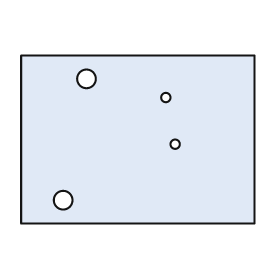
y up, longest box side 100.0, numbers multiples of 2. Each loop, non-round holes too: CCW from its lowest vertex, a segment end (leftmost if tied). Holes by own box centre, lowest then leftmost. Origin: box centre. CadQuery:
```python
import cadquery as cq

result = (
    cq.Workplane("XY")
    .moveTo(-50.0, -36.0)
    .lineTo(50.0, -36.0)
    .lineTo(50.0, 36.0)
    .lineTo(-50.0, 36.0)
    .close()
    .moveTo(-32.0, -26.0)
    .circle(4.0)
    .moveTo(16.0, -2.0)
    .circle(2.0)
    .moveTo(12.0, 18.0)
    .circle(2.0)
    .moveTo(-22.0, 26.0)
    .circle(4.0)
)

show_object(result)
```